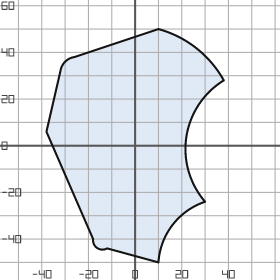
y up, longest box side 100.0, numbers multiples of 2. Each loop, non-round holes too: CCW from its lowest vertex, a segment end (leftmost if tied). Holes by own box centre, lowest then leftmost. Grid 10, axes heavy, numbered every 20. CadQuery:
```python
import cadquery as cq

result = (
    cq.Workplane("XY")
    .moveTo(10.0, -50.0)
    .threePointArc((16.0, -34.0), (30.0, -24.0))
    .threePointArc((22.0, 4.0), (38.0, 28.0))
    .threePointArc((26.0, 42.0), (10.0, 50.0))
    .lineTo(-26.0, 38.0)
    .threePointArc((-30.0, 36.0), (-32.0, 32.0))
    .lineTo(-38.0, 6.0)
    .lineTo(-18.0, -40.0)
    .threePointArc((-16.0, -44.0), (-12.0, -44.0))
    .close()
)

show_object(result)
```